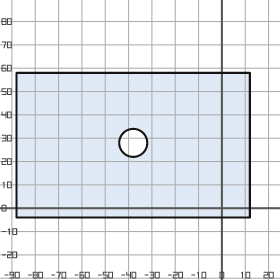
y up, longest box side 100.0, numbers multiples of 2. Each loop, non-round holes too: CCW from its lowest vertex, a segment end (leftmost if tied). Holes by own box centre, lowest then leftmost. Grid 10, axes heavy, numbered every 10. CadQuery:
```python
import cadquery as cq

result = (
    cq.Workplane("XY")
    .moveTo(-88.0, -4.0)
    .lineTo(12.0, -4.0)
    .lineTo(12.0, 58.0)
    .lineTo(-88.0, 58.0)
    .close()
    .moveTo(-38.0, 28.0)
    .circle(6.0)
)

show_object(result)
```